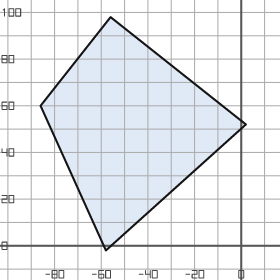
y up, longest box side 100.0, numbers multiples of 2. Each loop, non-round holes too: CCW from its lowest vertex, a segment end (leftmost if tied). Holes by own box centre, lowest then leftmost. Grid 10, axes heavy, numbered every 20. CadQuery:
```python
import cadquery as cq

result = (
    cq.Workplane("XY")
    .moveTo(-58.0, -2.0)
    .lineTo(2.0, 52.0)
    .lineTo(-56.0, 98.0)
    .lineTo(-86.0, 60.0)
    .close()
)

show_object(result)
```